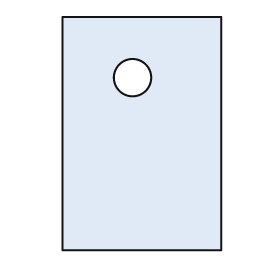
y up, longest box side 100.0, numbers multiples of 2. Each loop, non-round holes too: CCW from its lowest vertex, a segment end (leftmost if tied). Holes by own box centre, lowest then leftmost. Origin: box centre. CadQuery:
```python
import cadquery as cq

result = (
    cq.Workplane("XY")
    .moveTo(-34.0, -50.0)
    .lineTo(34.0, -50.0)
    .lineTo(34.0, 50.0)
    .lineTo(-34.0, 50.0)
    .close()
    .moveTo(-4.0, 24.0)
    .circle(8.0)
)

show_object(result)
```